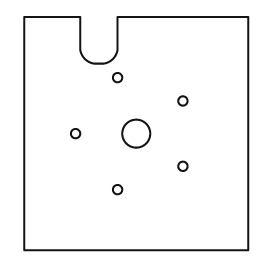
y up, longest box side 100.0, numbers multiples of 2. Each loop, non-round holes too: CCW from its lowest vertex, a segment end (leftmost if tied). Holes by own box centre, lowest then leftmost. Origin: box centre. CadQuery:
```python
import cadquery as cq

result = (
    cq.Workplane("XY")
    .moveTo(-48.0, -50.0)
    .lineTo(48.0, -50.0)
    .lineTo(48.0, 50.0)
    .lineTo(-8.0, 50.0)
    .lineTo(-8.0, 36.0)
    .threePointArc((-10.0, 32.0), (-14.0, 30.0))
    .lineTo(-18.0, 30.0)
    .threePointArc((-22.0, 32.0), (-24.0, 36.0))
    .lineTo(-24.0, 50.0)
    .lineTo(-48.0, 50.0)
    .close()
    .moveTo(-8.0, -24.0)
    .circle(2.0)
    .moveTo(20.0, -14.0)
    .circle(2.0)
    .moveTo(-26.0, 0.0)
    .circle(2.0)
    .moveTo(0.0, 0.0)
    .circle(6.0)
    .moveTo(20.0, 14.0)
    .circle(2.0)
    .moveTo(-8.0, 24.0)
    .circle(2.0)
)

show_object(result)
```